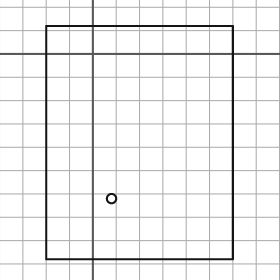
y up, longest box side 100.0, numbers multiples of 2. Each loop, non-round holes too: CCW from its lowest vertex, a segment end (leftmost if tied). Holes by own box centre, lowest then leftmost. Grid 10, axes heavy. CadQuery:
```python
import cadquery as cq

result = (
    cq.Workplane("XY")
    .moveTo(-20.0, -88.0)
    .lineTo(60.0, -88.0)
    .lineTo(60.0, 12.0)
    .lineTo(-20.0, 12.0)
    .close()
    .moveTo(8.0, -62.0)
    .circle(2.0)
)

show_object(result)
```